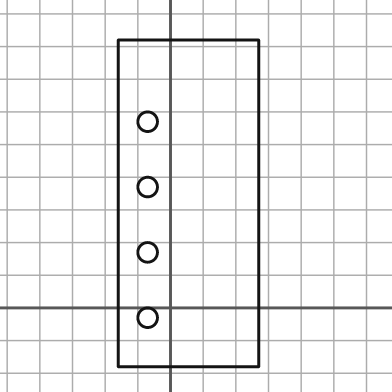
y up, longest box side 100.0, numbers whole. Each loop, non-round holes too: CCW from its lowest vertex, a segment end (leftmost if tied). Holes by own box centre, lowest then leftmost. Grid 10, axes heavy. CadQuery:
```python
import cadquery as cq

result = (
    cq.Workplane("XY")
    .moveTo(-16.0, -18.0)
    .lineTo(27.0, -18.0)
    .lineTo(27.0, 82.0)
    .lineTo(-16.0, 82.0)
    .close()
    .moveTo(-7.0, -3.0)
    .circle(3.0)
    .moveTo(-7.0, 17.0)
    .circle(3.0)
    .moveTo(-7.0, 37.0)
    .circle(3.0)
    .moveTo(-7.0, 57.0)
    .circle(3.0)
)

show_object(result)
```